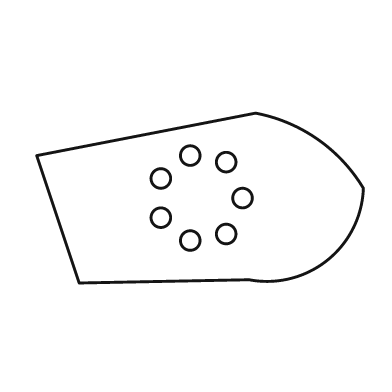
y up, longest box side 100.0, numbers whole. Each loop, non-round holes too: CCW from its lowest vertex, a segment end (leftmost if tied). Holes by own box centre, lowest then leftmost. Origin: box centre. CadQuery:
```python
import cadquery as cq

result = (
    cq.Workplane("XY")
    .moveTo(-37.0, -26.0)
    .lineTo(15.0, -25.0)
    .threePointArc((39.0, -19.0), (50.0, 3.0))
    .threePointArc((36.0, 18.0), (17.0, 26.0))
    .lineTo(-50.0, 13.0)
    .close()
    .moveTo(-3.0, -13.0)
    .circle(3.0)
    .moveTo(8.0, -11.0)
    .circle(3.0)
    .moveTo(-12.0, -6.0)
    .circle(3.0)
    .moveTo(13.0, 0.0)
    .circle(3.0)
    .moveTo(-12.0, 6.0)
    .circle(3.0)
    .moveTo(8.0, 11.0)
    .circle(3.0)
    .moveTo(-3.0, 13.0)
    .circle(3.0)
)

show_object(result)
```